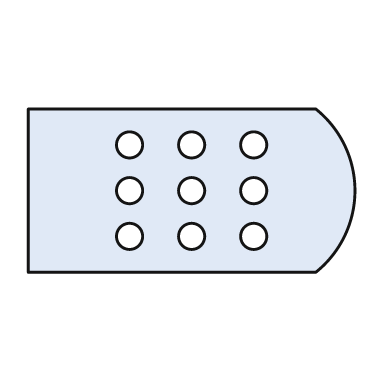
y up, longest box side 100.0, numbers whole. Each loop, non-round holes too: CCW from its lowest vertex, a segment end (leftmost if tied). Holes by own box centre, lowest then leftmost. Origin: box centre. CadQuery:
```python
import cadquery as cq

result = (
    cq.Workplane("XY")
    .moveTo(-50.0, -25.0)
    .lineTo(38.0, -25.0)
    .threePointArc((50.0, 0.0), (38.0, 25.0))
    .lineTo(-50.0, 25.0)
    .close()
    .moveTo(-19.0, -14.0)
    .circle(4.0)
    .moveTo(0.0, -14.0)
    .circle(4.0)
    .moveTo(19.0, -14.0)
    .circle(4.0)
    .moveTo(-19.0, 0.0)
    .circle(4.0)
    .moveTo(0.0, 0.0)
    .circle(4.0)
    .moveTo(19.0, 0.0)
    .circle(4.0)
    .moveTo(-19.0, 14.0)
    .circle(4.0)
    .moveTo(0.0, 14.0)
    .circle(4.0)
    .moveTo(19.0, 14.0)
    .circle(4.0)
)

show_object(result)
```